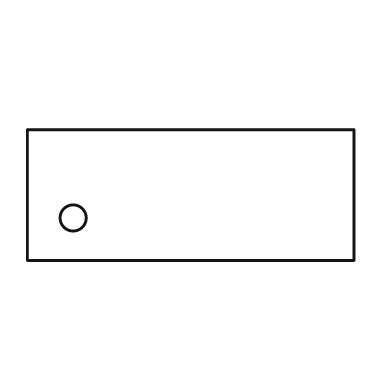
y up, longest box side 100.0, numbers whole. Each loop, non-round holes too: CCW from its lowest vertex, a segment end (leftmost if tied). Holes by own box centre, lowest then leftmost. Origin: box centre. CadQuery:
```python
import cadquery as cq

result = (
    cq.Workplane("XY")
    .moveTo(-50.0, -20.0)
    .lineTo(50.0, -20.0)
    .lineTo(50.0, 20.0)
    .lineTo(-50.0, 20.0)
    .close()
    .moveTo(-36.0, -7.0)
    .circle(4.0)
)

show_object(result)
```